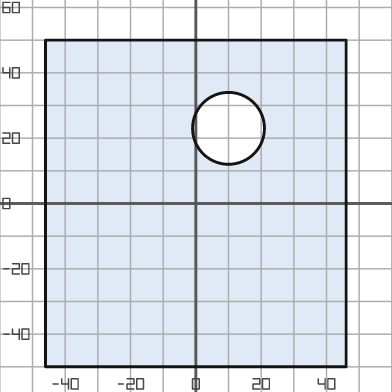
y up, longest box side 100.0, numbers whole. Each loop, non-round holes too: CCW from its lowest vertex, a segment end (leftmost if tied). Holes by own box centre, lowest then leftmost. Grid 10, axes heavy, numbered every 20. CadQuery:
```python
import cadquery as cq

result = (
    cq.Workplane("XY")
    .moveTo(-46.0, -50.0)
    .lineTo(46.0, -50.0)
    .lineTo(46.0, 50.0)
    .lineTo(-46.0, 50.0)
    .close()
    .moveTo(10.0, 23.0)
    .circle(11.0)
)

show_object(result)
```